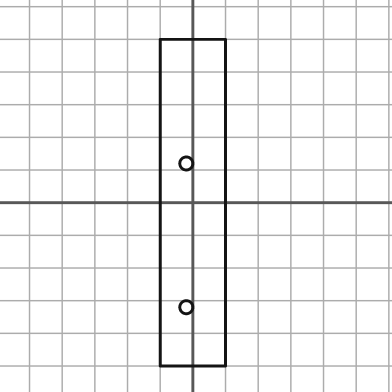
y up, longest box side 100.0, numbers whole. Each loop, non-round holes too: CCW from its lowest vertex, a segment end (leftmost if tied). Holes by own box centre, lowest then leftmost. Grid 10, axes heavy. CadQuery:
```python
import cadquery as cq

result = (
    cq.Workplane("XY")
    .moveTo(-10.0, -50.0)
    .lineTo(10.0, -50.0)
    .lineTo(10.0, 50.0)
    .lineTo(-10.0, 50.0)
    .close()
    .moveTo(-2.0, -32.0)
    .circle(2.0)
    .moveTo(-2.0, 12.0)
    .circle(2.0)
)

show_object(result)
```